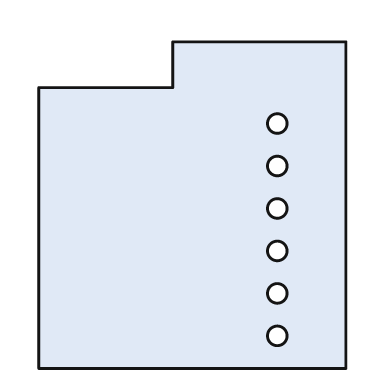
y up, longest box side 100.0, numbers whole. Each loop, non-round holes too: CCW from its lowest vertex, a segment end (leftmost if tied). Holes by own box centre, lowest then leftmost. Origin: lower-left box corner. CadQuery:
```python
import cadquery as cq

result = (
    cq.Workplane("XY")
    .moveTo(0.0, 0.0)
    .lineTo(94.0, 0.0)
    .lineTo(94.0, 100.0)
    .lineTo(41.0, 100.0)
    .lineTo(41.0, 86.0)
    .lineTo(0.0, 86.0)
    .close()
    .moveTo(73.0, 10.0)
    .circle(3.0)
    .moveTo(73.0, 23.0)
    .circle(3.0)
    .moveTo(73.0, 36.0)
    .circle(3.0)
    .moveTo(73.0, 49.0)
    .circle(3.0)
    .moveTo(73.0, 62.0)
    .circle(3.0)
    .moveTo(73.0, 75.0)
    .circle(3.0)
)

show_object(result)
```